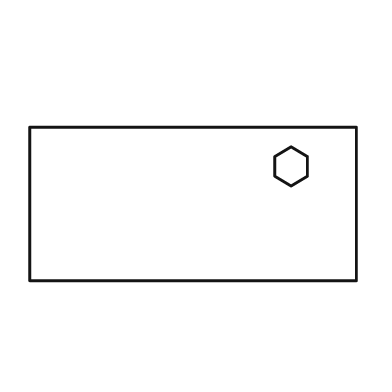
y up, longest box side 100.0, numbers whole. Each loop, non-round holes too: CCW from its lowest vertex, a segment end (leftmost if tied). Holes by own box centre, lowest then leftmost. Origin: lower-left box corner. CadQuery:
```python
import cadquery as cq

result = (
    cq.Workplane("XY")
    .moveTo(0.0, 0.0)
    .lineTo(100.0, 0.0)
    .lineTo(100.0, 47.0)
    .lineTo(0.0, 47.0)
    .close()
    .moveTo(80.0, 29.0)
    .lineTo(85.0, 32.0)
    .lineTo(85.0, 38.0)
    .lineTo(80.0, 41.0)
    .lineTo(75.0, 38.0)
    .lineTo(75.0, 32.0)
    .close()
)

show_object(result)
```